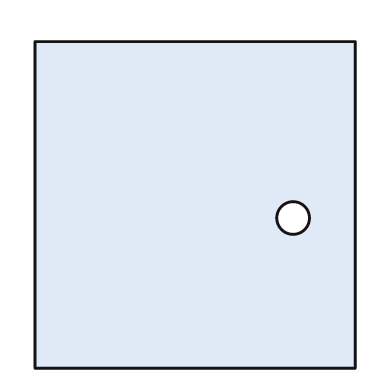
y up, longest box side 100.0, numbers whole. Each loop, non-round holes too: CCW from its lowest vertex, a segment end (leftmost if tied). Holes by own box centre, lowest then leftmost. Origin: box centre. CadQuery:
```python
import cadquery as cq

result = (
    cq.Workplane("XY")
    .moveTo(-49.0, -50.0)
    .lineTo(49.0, -50.0)
    .lineTo(49.0, 50.0)
    .lineTo(-49.0, 50.0)
    .close()
    .moveTo(30.0, -4.0)
    .circle(5.0)
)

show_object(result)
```